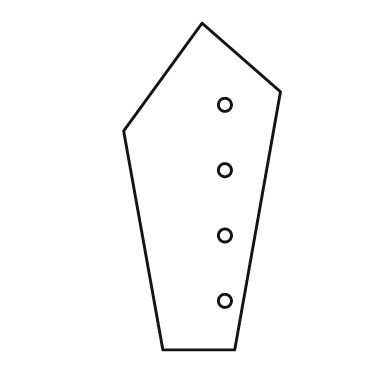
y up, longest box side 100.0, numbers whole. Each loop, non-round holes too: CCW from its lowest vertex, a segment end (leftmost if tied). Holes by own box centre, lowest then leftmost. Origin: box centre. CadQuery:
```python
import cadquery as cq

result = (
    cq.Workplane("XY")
    .moveTo(-12.0, -50.0)
    .lineTo(10.0, -50.0)
    .lineTo(24.0, 29.0)
    .lineTo(0.0, 50.0)
    .lineTo(-24.0, 17.0)
    .close()
    .moveTo(7.0, -35.0)
    .circle(2.0)
    .moveTo(7.0, -15.0)
    .circle(2.0)
    .moveTo(7.0, 5.0)
    .circle(2.0)
    .moveTo(7.0, 25.0)
    .circle(2.0)
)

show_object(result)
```